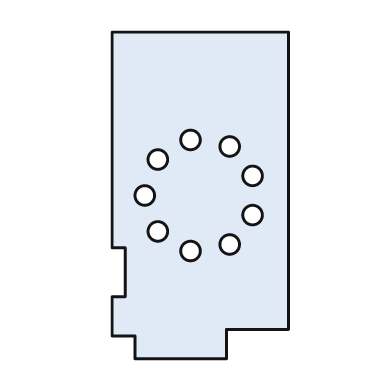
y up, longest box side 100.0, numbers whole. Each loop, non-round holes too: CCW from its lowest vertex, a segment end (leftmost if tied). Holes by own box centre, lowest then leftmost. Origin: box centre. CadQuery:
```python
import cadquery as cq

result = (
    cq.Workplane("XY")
    .moveTo(-20.0, -50.0)
    .lineTo(8.0, -50.0)
    .lineTo(8.0, -41.0)
    .lineTo(27.0, -41.0)
    .lineTo(27.0, 50.0)
    .lineTo(-27.0, 50.0)
    .lineTo(-27.0, -16.0)
    .lineTo(-23.0, -16.0)
    .lineTo(-23.0, -31.0)
    .lineTo(-27.0, -31.0)
    .lineTo(-27.0, -43.0)
    .lineTo(-20.0, -43.0)
    .close()
    .moveTo(-3.0, -17.0)
    .circle(3.0)
    .moveTo(9.0, -15.0)
    .circle(3.0)
    .moveTo(-13.0, -11.0)
    .circle(3.0)
    .moveTo(16.0, -6.0)
    .circle(3.0)
    .moveTo(-17.0, 0.0)
    .circle(3.0)
    .moveTo(16.0, 6.0)
    .circle(3.0)
    .moveTo(-13.0, 11.0)
    .circle(3.0)
    .moveTo(9.0, 15.0)
    .circle(3.0)
    .moveTo(-3.0, 17.0)
    .circle(3.0)
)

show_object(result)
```